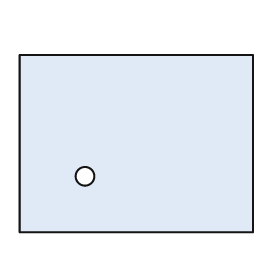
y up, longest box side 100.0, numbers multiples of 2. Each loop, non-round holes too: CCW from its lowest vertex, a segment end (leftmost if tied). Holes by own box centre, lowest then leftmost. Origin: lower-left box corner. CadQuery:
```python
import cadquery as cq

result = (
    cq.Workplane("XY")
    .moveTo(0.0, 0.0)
    .lineTo(100.0, 0.0)
    .lineTo(100.0, 76.0)
    .lineTo(0.0, 76.0)
    .close()
    .moveTo(28.0, 24.0)
    .circle(4.0)
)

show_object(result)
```